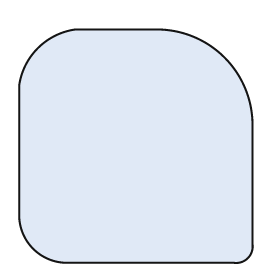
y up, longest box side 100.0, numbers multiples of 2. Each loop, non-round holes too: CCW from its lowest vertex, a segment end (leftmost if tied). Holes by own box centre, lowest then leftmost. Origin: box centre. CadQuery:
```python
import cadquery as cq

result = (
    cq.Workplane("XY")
    .moveTo(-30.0, -50.0)
    .lineTo(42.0, -50.0)
    .threePointArc((48.0, -48.0), (50.0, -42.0))
    .lineTo(50.0, 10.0)
    .threePointArc((38.0, 38.0), (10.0, 50.0))
    .lineTo(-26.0, 50.0)
    .threePointArc((-42.0, 42.0), (-50.0, 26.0))
    .lineTo(-50.0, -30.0)
    .threePointArc((-44.0, -44.0), (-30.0, -50.0))
    .close()
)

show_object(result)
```